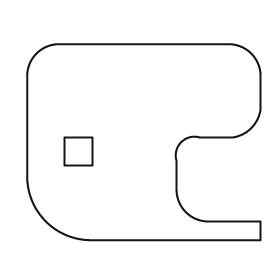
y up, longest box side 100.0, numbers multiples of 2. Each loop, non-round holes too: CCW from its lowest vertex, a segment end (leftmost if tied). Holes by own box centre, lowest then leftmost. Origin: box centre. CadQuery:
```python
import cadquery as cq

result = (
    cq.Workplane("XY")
    .moveTo(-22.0, -42.0)
    .lineTo(50.0, -42.0)
    .lineTo(50.0, -34.0)
    .lineTo(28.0, -34.0)
    .threePointArc((18.0, -30.0), (14.0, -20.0))
    .lineTo(14.0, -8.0)
    .threePointArc((16.0, 0.0), (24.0, 2.0))
    .lineTo(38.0, 2.0)
    .threePointArc((46.0, 6.0), (50.0, 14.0))
    .lineTo(50.0, 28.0)
    .threePointArc((46.0, 38.0), (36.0, 42.0))
    .lineTo(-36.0, 42.0)
    .threePointArc((-46.0, 38.0), (-50.0, 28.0))
    .lineTo(-50.0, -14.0)
    .threePointArc((-42.0, -34.0), (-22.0, -42.0))
    .close()
    .moveTo(-34.0, -10.0)
    .lineTo(-22.0, -10.0)
    .lineTo(-22.0, 2.0)
    .lineTo(-34.0, 2.0)
    .close()
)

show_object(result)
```